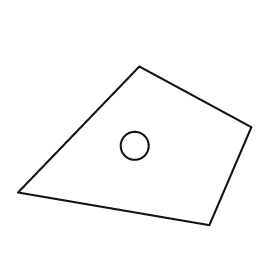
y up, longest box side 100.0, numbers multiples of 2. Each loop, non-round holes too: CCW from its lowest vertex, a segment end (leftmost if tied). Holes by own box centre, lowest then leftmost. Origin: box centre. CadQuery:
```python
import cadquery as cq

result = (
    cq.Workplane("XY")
    .moveTo(32.0, -34.0)
    .lineTo(50.0, 8.0)
    .lineTo(2.0, 34.0)
    .lineTo(-50.0, -20.0)
    .close()
    .moveTo(0.0, 0.0)
    .circle(6.0)
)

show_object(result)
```